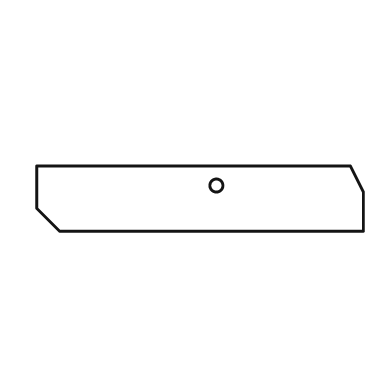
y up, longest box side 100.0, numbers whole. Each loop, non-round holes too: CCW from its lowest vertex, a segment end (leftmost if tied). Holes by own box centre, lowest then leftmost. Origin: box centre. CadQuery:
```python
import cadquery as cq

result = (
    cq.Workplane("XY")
    .moveTo(-43.0, -10.0)
    .lineTo(50.0, -10.0)
    .lineTo(50.0, 2.0)
    .lineTo(46.0, 10.0)
    .lineTo(-50.0, 10.0)
    .lineTo(-50.0, -3.0)
    .close()
    .moveTo(5.0, 4.0)
    .circle(2.0)
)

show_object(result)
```